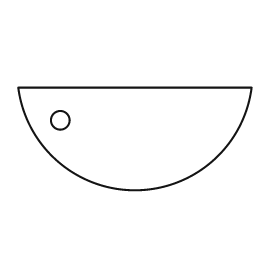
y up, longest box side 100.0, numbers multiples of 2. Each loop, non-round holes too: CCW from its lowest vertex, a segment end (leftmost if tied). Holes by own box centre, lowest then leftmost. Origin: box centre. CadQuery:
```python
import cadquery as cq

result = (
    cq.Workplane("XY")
    .moveTo(-50.0, 22.0)
    .threePointArc((0.0, -22.0), (50.0, 22.0))
    .close()
    .moveTo(-32.0, 8.0)
    .circle(4.0)
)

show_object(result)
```